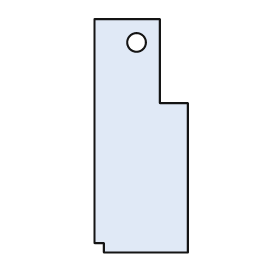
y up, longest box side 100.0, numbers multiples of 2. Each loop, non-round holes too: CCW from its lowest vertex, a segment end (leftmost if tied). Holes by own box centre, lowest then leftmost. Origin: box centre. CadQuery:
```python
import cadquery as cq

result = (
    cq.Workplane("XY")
    .moveTo(-16.0, -50.0)
    .lineTo(20.0, -50.0)
    .lineTo(20.0, 14.0)
    .lineTo(8.0, 14.0)
    .lineTo(8.0, 50.0)
    .lineTo(-20.0, 50.0)
    .lineTo(-20.0, -46.0)
    .lineTo(-16.0, -46.0)
    .close()
    .moveTo(-2.0, 40.0)
    .circle(4.0)
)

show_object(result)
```